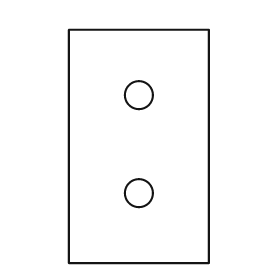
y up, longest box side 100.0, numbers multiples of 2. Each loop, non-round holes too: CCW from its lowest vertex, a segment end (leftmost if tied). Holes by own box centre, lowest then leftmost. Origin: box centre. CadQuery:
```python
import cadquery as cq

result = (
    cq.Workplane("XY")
    .moveTo(-30.0, -50.0)
    .lineTo(30.0, -50.0)
    .lineTo(30.0, 50.0)
    .lineTo(-30.0, 50.0)
    .close()
    .moveTo(0.0, -20.0)
    .circle(6.0)
    .moveTo(0.0, 22.0)
    .circle(6.0)
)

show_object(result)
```